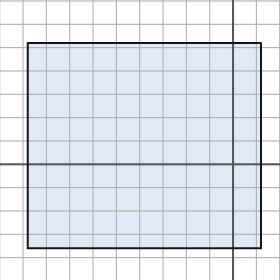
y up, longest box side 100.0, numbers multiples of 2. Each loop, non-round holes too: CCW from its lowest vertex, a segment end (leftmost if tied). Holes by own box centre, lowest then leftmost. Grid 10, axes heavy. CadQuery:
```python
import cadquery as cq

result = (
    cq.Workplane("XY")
    .moveTo(-88.0, -36.0)
    .lineTo(12.0, -36.0)
    .lineTo(12.0, 52.0)
    .lineTo(-88.0, 52.0)
    .close()
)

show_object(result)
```